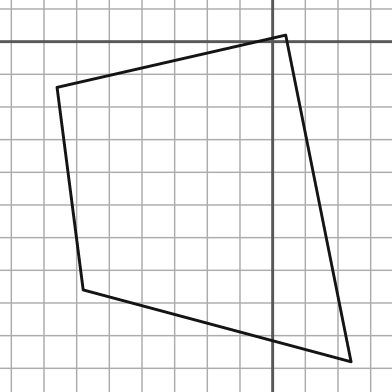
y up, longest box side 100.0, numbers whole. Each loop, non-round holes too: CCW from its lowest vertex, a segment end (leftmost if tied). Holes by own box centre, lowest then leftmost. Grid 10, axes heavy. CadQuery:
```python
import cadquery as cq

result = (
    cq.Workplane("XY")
    .moveTo(24.0, -98.0)
    .lineTo(4.0, 2.0)
    .lineTo(-66.0, -14.0)
    .lineTo(-58.0, -76.0)
    .close()
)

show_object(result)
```